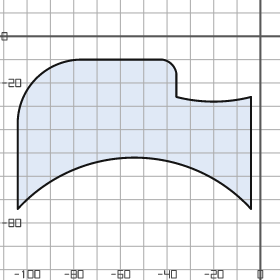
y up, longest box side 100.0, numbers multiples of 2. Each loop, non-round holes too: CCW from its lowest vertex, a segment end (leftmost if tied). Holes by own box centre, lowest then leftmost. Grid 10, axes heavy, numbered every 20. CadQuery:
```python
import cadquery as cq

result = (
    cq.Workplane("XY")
    .moveTo(-104.0, -74.0)
    .threePointArc((-54.0, -52.0), (-4.0, -74.0))
    .lineTo(-4.0, -26.0)
    .threePointArc((-20.0, -28.0), (-36.0, -26.0))
    .lineTo(-36.0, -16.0)
    .threePointArc((-38.0, -12.0), (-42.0, -10.0))
    .lineTo(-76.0, -10.0)
    .threePointArc((-96.0, -18.0), (-104.0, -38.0))
    .close()
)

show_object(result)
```